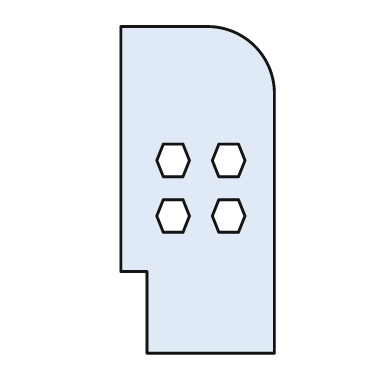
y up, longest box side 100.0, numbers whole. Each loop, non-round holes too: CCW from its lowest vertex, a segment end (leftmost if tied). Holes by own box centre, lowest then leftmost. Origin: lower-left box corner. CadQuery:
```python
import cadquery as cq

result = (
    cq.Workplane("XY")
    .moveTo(8.0, 0.0)
    .lineTo(47.0, 0.0)
    .lineTo(47.0, 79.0)
    .threePointArc((41.0, 94.0), (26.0, 100.0))
    .lineTo(0.0, 100.0)
    .lineTo(0.0, 25.0)
    .lineTo(8.0, 25.0)
    .close()
    .moveTo(13.0, 37.0)
    .lineTo(19.0, 37.0)
    .lineTo(21.0, 42.0)
    .lineTo(19.0, 47.0)
    .lineTo(13.0, 47.0)
    .lineTo(11.0, 42.0)
    .close()
    .moveTo(30.0, 37.0)
    .lineTo(36.0, 37.0)
    .lineTo(38.0, 42.0)
    .lineTo(36.0, 47.0)
    .lineTo(30.0, 47.0)
    .lineTo(28.0, 42.0)
    .close()
    .moveTo(13.0, 54.0)
    .lineTo(19.0, 54.0)
    .lineTo(21.0, 59.0)
    .lineTo(19.0, 64.0)
    .lineTo(13.0, 64.0)
    .lineTo(11.0, 59.0)
    .close()
    .moveTo(30.0, 54.0)
    .lineTo(36.0, 54.0)
    .lineTo(38.0, 59.0)
    .lineTo(36.0, 64.0)
    .lineTo(30.0, 64.0)
    .lineTo(28.0, 59.0)
    .close()
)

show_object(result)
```